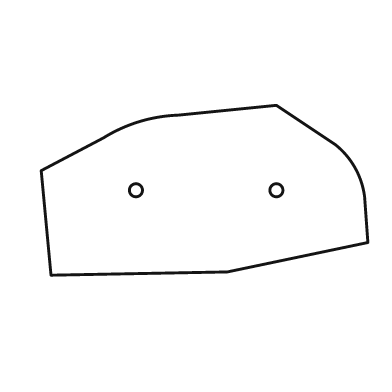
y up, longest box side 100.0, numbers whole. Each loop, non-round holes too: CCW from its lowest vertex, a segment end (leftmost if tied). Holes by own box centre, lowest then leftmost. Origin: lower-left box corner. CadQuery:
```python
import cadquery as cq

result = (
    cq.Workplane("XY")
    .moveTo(3.0, 0.0)
    .lineTo(57.0, 1.0)
    .lineTo(100.0, 10.0)
    .lineTo(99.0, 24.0)
    .threePointArc((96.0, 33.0), (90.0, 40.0))
    .lineTo(72.0, 52.0)
    .lineTo(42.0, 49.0)
    .threePointArc((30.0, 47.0), (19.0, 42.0))
    .lineTo(0.0, 32.0)
    .close()
    .moveTo(29.0, 26.0)
    .circle(2.0)
    .moveTo(72.0, 26.0)
    .circle(2.0)
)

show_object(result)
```